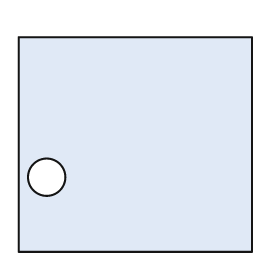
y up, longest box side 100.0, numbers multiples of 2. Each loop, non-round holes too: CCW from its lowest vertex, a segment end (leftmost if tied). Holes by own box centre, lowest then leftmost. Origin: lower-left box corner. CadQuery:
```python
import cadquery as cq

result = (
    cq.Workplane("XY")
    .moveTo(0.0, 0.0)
    .lineTo(100.0, 0.0)
    .lineTo(100.0, 92.0)
    .lineTo(0.0, 92.0)
    .close()
    .moveTo(12.0, 32.0)
    .circle(8.0)
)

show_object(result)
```